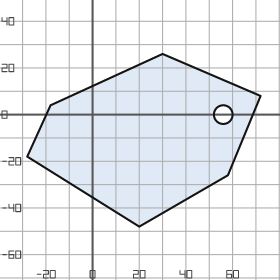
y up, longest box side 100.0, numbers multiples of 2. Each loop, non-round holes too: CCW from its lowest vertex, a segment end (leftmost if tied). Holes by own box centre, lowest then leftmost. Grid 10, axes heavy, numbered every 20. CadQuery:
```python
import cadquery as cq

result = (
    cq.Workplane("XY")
    .moveTo(20.0, -48.0)
    .lineTo(58.0, -26.0)
    .lineTo(72.0, 8.0)
    .lineTo(30.0, 26.0)
    .lineTo(-18.0, 4.0)
    .lineTo(-28.0, -18.0)
    .close()
    .moveTo(56.0, 0.0)
    .circle(4.0)
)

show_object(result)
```